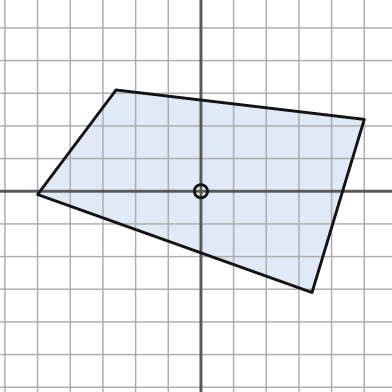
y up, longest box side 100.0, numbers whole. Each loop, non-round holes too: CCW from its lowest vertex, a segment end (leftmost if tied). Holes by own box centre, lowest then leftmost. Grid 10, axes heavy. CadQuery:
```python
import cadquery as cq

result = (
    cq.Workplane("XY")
    .moveTo(34.0, -31.0)
    .lineTo(50.0, 22.0)
    .lineTo(-26.0, 31.0)
    .lineTo(-50.0, -1.0)
    .close()
    .moveTo(0.0, 0.0)
    .circle(2.0)
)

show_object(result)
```